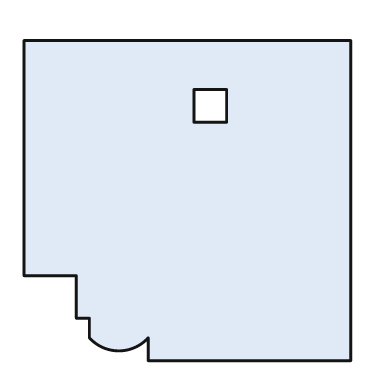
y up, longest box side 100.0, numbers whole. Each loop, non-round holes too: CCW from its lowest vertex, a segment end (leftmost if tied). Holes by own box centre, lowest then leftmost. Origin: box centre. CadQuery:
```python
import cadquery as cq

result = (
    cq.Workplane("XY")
    .moveTo(-12.0, -49.0)
    .lineTo(50.0, -49.0)
    .lineTo(50.0, 49.0)
    .lineTo(-50.0, 49.0)
    .lineTo(-50.0, -23.0)
    .lineTo(-34.0, -23.0)
    .lineTo(-34.0, -36.0)
    .lineTo(-30.0, -36.0)
    .lineTo(-30.0, -42.0)
    .threePointArc((-21.0, -46.0), (-12.0, -42.0))
    .close()
    .moveTo(2.0, 24.0)
    .lineTo(12.0, 24.0)
    .lineTo(12.0, 34.0)
    .lineTo(2.0, 34.0)
    .close()
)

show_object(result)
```